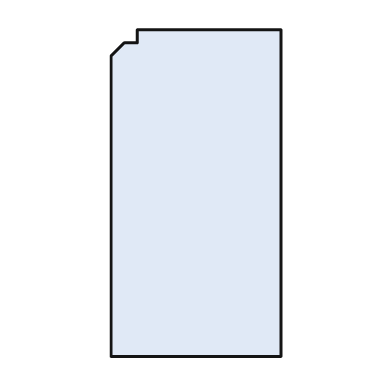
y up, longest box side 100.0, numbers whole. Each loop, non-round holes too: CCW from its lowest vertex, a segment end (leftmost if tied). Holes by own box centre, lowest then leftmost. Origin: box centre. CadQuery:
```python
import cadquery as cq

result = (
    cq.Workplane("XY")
    .moveTo(-26.0, -50.0)
    .lineTo(26.0, -50.0)
    .lineTo(26.0, 50.0)
    .lineTo(-18.0, 50.0)
    .lineTo(-18.0, 46.0)
    .lineTo(-22.0, 46.0)
    .lineTo(-26.0, 42.0)
    .close()
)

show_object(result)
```